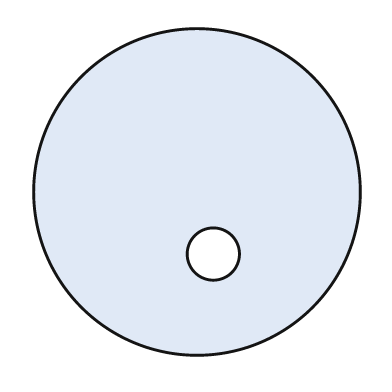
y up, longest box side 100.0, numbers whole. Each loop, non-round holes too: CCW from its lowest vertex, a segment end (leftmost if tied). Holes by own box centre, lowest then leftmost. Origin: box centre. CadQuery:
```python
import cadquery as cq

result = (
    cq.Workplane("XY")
    .moveTo(0.0, 0.0)
    .circle(50.0)
    .moveTo(5.0, -19.0)
    .circle(8.0)
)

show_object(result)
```